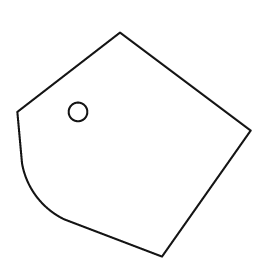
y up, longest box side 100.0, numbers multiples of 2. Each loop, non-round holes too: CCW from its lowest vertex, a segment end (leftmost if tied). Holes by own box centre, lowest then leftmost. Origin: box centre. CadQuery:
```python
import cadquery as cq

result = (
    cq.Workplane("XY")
    .moveTo(12.0, -48.0)
    .lineTo(50.0, 6.0)
    .lineTo(-6.0, 48.0)
    .lineTo(-50.0, 14.0)
    .lineTo(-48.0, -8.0)
    .threePointArc((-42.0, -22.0), (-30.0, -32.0))
    .close()
    .moveTo(-24.0, 14.0)
    .circle(4.0)
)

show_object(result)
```